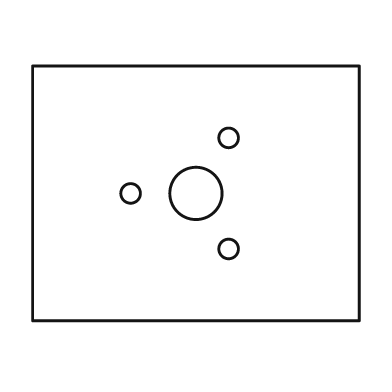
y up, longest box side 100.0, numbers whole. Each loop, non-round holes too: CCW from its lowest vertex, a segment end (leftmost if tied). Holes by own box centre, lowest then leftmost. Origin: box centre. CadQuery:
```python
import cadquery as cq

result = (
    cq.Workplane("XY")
    .moveTo(-50.0, -39.0)
    .lineTo(50.0, -39.0)
    .lineTo(50.0, 39.0)
    .lineTo(-50.0, 39.0)
    .close()
    .moveTo(10.0, -17.0)
    .circle(3.0)
    .moveTo(-20.0, 0.0)
    .circle(3.0)
    .moveTo(0.0, 0.0)
    .circle(8.0)
    .moveTo(10.0, 17.0)
    .circle(3.0)
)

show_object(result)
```